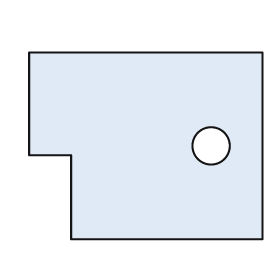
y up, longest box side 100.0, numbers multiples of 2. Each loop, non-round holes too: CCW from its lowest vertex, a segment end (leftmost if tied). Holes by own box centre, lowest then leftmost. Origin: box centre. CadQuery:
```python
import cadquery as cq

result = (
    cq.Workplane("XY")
    .moveTo(-32.0, -40.0)
    .lineTo(50.0, -40.0)
    .lineTo(50.0, 40.0)
    .lineTo(-50.0, 40.0)
    .lineTo(-50.0, -4.0)
    .lineTo(-32.0, -4.0)
    .close()
    .moveTo(28.0, 0.0)
    .circle(8.0)
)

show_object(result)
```